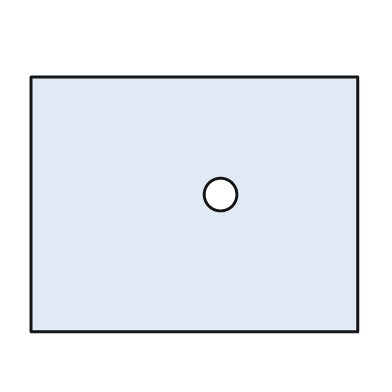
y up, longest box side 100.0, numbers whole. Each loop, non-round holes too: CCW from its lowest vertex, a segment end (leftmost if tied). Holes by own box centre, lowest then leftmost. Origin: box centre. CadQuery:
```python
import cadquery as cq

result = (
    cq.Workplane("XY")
    .moveTo(-50.0, -39.0)
    .lineTo(50.0, -39.0)
    .lineTo(50.0, 39.0)
    .lineTo(-50.0, 39.0)
    .close()
    .moveTo(8.0, 3.0)
    .circle(5.0)
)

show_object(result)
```